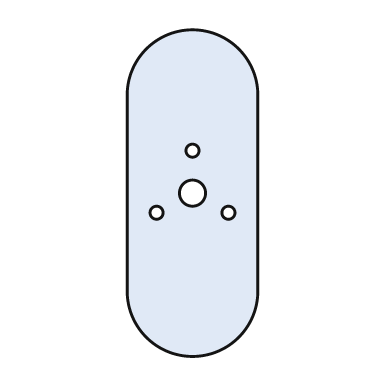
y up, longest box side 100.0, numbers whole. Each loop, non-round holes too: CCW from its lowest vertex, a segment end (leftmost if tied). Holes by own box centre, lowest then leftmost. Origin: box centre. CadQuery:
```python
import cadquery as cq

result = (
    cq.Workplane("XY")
    .moveTo(-20.0, -30.0)
    .threePointArc((0.0, -50.0), (20.0, -30.0))
    .lineTo(20.0, 30.0)
    .threePointArc((0.0, 50.0), (-20.0, 30.0))
    .close()
    .moveTo(-11.0, -6.0)
    .circle(2.0)
    .moveTo(11.0, -6.0)
    .circle(2.0)
    .moveTo(0.0, 0.0)
    .circle(4.0)
    .moveTo(0.0, 13.0)
    .circle(2.0)
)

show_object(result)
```